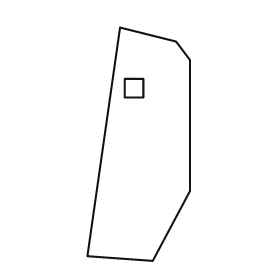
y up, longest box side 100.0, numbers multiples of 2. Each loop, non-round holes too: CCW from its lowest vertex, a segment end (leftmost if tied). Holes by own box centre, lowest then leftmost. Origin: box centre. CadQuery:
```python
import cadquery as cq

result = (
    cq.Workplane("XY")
    .moveTo(6.0, -50.0)
    .lineTo(22.0, -20.0)
    .lineTo(22.0, 36.0)
    .lineTo(16.0, 44.0)
    .lineTo(-8.0, 50.0)
    .lineTo(-22.0, -48.0)
    .close()
    .moveTo(-6.0, 20.0)
    .lineTo(2.0, 20.0)
    .lineTo(2.0, 28.0)
    .lineTo(-6.0, 28.0)
    .close()
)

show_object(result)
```